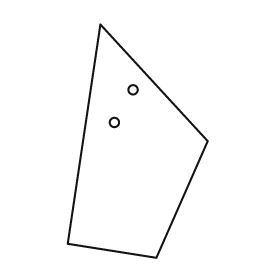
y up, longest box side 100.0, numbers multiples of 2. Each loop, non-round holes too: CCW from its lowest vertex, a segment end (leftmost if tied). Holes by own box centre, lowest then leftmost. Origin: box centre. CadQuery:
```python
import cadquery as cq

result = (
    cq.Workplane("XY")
    .moveTo(8.0, -50.0)
    .lineTo(30.0, 0.0)
    .lineTo(-16.0, 50.0)
    .lineTo(-30.0, -44.0)
    .close()
    .moveTo(-10.0, 8.0)
    .circle(2.0)
    .moveTo(-2.0, 22.0)
    .circle(2.0)
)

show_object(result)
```